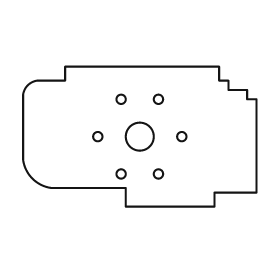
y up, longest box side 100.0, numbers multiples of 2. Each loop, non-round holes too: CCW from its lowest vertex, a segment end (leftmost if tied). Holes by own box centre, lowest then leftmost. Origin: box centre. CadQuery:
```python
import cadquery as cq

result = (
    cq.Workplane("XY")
    .moveTo(-6.0, -30.0)
    .lineTo(32.0, -30.0)
    .lineTo(32.0, -24.0)
    .lineTo(50.0, -24.0)
    .lineTo(50.0, 16.0)
    .lineTo(46.0, 16.0)
    .lineTo(46.0, 20.0)
    .lineTo(38.0, 20.0)
    .lineTo(38.0, 24.0)
    .lineTo(34.0, 24.0)
    .lineTo(34.0, 30.0)
    .lineTo(-32.0, 30.0)
    .lineTo(-32.0, 24.0)
    .lineTo(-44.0, 24.0)
    .threePointArc((-48.0, 22.0), (-50.0, 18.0))
    .lineTo(-50.0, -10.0)
    .threePointArc((-46.0, -18.0), (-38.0, -22.0))
    .lineTo(-6.0, -22.0)
    .close()
    .moveTo(-8.0, -16.0)
    .circle(2.0)
    .moveTo(8.0, -16.0)
    .circle(2.0)
    .moveTo(-18.0, 0.0)
    .circle(2.0)
    .moveTo(0.0, 0.0)
    .circle(6.0)
    .moveTo(18.0, 0.0)
    .circle(2.0)
    .moveTo(-8.0, 16.0)
    .circle(2.0)
    .moveTo(8.0, 16.0)
    .circle(2.0)
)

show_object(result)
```